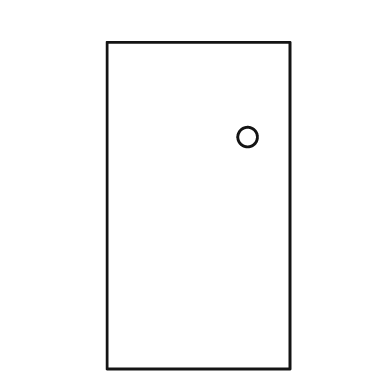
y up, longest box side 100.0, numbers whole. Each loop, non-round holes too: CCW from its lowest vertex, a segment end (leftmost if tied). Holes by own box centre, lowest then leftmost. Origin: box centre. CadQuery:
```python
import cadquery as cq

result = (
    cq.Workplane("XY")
    .moveTo(-28.0, -50.0)
    .lineTo(28.0, -50.0)
    .lineTo(28.0, 50.0)
    .lineTo(-28.0, 50.0)
    .close()
    .moveTo(15.0, 21.0)
    .circle(3.0)
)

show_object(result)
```